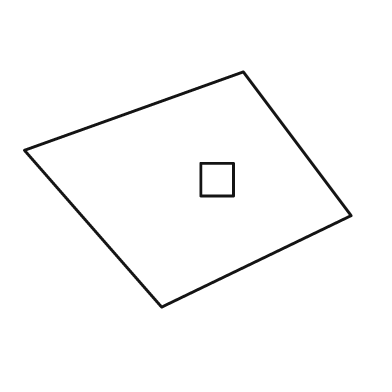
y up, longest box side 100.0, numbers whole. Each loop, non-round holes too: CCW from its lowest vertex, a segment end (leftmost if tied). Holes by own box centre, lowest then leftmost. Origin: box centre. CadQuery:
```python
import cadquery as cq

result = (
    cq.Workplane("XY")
    .moveTo(-8.0, -36.0)
    .lineTo(50.0, -8.0)
    .lineTo(17.0, 36.0)
    .lineTo(-50.0, 12.0)
    .close()
    .moveTo(4.0, -2.0)
    .lineTo(14.0, -2.0)
    .lineTo(14.0, 8.0)
    .lineTo(4.0, 8.0)
    .close()
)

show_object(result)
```